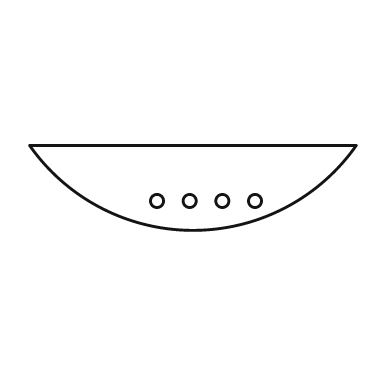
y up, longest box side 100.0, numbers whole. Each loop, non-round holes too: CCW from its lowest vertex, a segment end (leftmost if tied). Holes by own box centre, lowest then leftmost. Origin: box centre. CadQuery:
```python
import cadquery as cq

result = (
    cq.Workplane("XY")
    .moveTo(-50.0, 13.0)
    .threePointArc((0.0, -13.0), (50.0, 13.0))
    .close()
    .moveTo(-11.0, -4.0)
    .circle(2.0)
    .moveTo(-1.0, -4.0)
    .circle(2.0)
    .moveTo(9.0, -4.0)
    .circle(2.0)
    .moveTo(19.0, -4.0)
    .circle(2.0)
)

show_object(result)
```